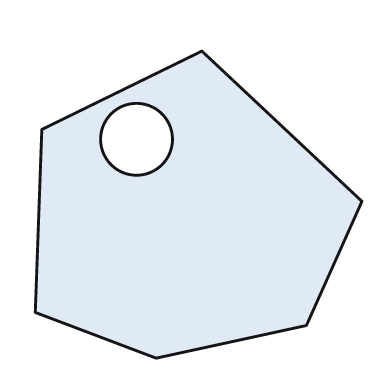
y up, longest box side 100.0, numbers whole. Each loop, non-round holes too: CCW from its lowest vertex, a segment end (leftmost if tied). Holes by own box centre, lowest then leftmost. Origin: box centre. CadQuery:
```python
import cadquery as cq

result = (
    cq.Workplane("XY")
    .moveTo(-13.0, -47.0)
    .lineTo(33.0, -37.0)
    .lineTo(50.0, 1.0)
    .lineTo(1.0, 47.0)
    .lineTo(-48.0, 23.0)
    .lineTo(-50.0, -33.0)
    .close()
    .moveTo(-19.0, 20.0)
    .circle(11.0)
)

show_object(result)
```